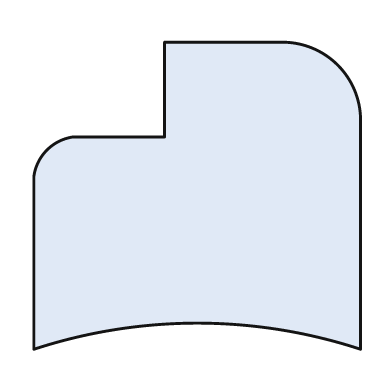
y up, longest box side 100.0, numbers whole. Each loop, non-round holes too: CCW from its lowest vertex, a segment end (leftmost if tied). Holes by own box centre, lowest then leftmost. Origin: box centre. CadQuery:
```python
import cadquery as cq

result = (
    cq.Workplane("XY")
    .moveTo(-50.0, -47.0)
    .threePointArc((0.0, -39.0), (50.0, -47.0))
    .lineTo(50.0, 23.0)
    .threePointArc((43.0, 40.0), (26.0, 47.0))
    .lineTo(-10.0, 47.0)
    .lineTo(-10.0, 18.0)
    .lineTo(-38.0, 18.0)
    .threePointArc((-46.0, 14.0), (-50.0, 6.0))
    .close()
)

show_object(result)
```